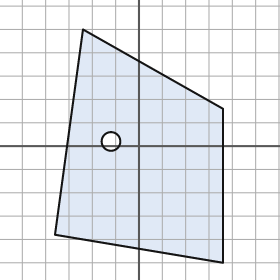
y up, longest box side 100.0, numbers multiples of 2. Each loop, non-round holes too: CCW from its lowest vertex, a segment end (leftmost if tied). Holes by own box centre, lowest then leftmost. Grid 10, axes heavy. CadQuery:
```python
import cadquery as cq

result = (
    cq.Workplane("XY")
    .moveTo(36.0, -50.0)
    .lineTo(36.0, 16.0)
    .lineTo(-24.0, 50.0)
    .lineTo(-36.0, -38.0)
    .close()
    .moveTo(-12.0, 2.0)
    .circle(4.0)
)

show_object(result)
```